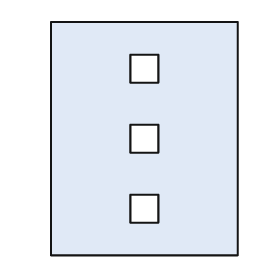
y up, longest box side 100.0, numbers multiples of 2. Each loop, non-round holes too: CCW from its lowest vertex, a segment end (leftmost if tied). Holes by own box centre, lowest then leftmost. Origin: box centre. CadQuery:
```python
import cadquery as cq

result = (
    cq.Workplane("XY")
    .moveTo(-40.0, -50.0)
    .lineTo(40.0, -50.0)
    .lineTo(40.0, 50.0)
    .lineTo(-40.0, 50.0)
    .close()
    .moveTo(-6.0, -36.0)
    .lineTo(6.0, -36.0)
    .lineTo(6.0, -24.0)
    .lineTo(-6.0, -24.0)
    .close()
    .moveTo(-6.0, -6.0)
    .lineTo(6.0, -6.0)
    .lineTo(6.0, 6.0)
    .lineTo(-6.0, 6.0)
    .close()
    .moveTo(-6.0, 24.0)
    .lineTo(6.0, 24.0)
    .lineTo(6.0, 36.0)
    .lineTo(-6.0, 36.0)
    .close()
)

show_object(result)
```